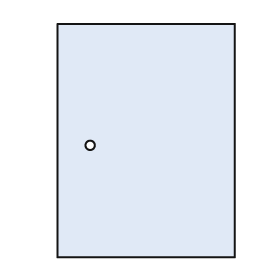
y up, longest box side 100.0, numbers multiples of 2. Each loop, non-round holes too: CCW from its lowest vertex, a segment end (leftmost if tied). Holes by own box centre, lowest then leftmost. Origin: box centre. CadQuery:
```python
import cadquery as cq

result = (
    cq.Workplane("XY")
    .moveTo(-38.0, -50.0)
    .lineTo(38.0, -50.0)
    .lineTo(38.0, 50.0)
    .lineTo(-38.0, 50.0)
    .close()
    .moveTo(-24.0, -2.0)
    .circle(2.0)
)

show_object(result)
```